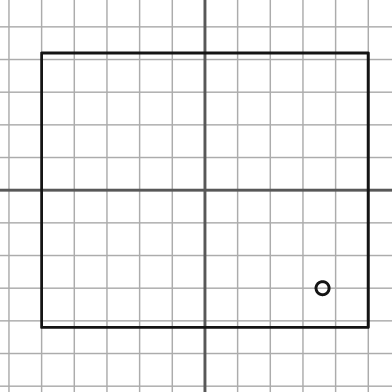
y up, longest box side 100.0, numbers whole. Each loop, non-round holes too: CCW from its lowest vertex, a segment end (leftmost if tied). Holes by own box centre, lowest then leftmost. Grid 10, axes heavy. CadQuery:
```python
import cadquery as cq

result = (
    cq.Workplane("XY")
    .moveTo(-50.0, -42.0)
    .lineTo(50.0, -42.0)
    .lineTo(50.0, 42.0)
    .lineTo(-50.0, 42.0)
    .close()
    .moveTo(36.0, -30.0)
    .circle(2.0)
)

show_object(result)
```